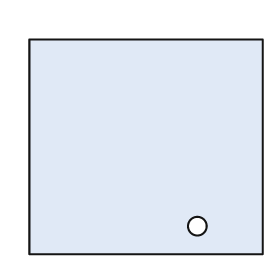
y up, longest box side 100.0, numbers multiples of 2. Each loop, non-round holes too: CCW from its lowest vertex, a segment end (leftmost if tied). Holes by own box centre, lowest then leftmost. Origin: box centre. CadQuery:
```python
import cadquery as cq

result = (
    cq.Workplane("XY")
    .moveTo(-50.0, -46.0)
    .lineTo(50.0, -46.0)
    .lineTo(50.0, 46.0)
    .lineTo(-50.0, 46.0)
    .close()
    .moveTo(22.0, -34.0)
    .circle(4.0)
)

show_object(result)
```